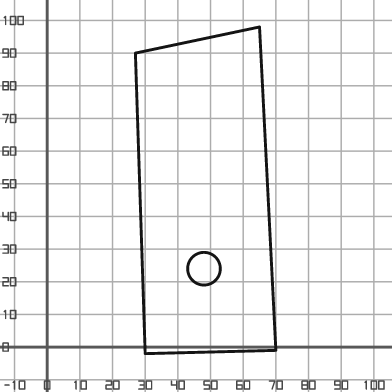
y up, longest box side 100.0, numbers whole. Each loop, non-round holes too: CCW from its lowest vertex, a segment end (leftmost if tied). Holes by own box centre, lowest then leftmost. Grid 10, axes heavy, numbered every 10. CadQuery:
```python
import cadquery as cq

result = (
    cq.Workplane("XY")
    .moveTo(30.0, -2.0)
    .lineTo(70.0, -1.0)
    .lineTo(65.0, 98.0)
    .lineTo(27.0, 90.0)
    .close()
    .moveTo(48.0, 24.0)
    .circle(5.0)
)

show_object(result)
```